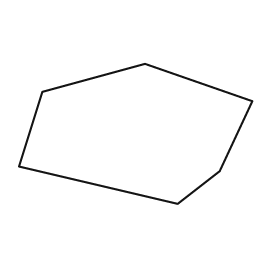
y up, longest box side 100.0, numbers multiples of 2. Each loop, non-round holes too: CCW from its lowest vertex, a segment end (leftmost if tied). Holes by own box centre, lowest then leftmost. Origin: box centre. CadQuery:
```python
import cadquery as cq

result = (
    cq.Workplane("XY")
    .moveTo(18.0, -30.0)
    .lineTo(36.0, -16.0)
    .lineTo(50.0, 14.0)
    .lineTo(4.0, 30.0)
    .lineTo(-40.0, 18.0)
    .lineTo(-50.0, -14.0)
    .close()
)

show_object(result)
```